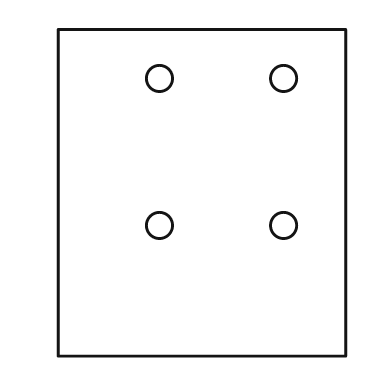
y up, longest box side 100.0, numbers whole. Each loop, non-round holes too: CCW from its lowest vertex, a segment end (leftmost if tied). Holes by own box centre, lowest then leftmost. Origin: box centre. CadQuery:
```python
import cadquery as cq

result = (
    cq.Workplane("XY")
    .moveTo(-44.0, -50.0)
    .lineTo(44.0, -50.0)
    .lineTo(44.0, 50.0)
    .lineTo(-44.0, 50.0)
    .close()
    .moveTo(-13.0, -10.0)
    .circle(4.0)
    .moveTo(25.0, -10.0)
    .circle(4.0)
    .moveTo(-13.0, 35.0)
    .circle(4.0)
    .moveTo(25.0, 35.0)
    .circle(4.0)
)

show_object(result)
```